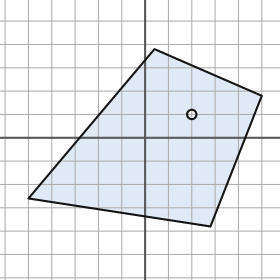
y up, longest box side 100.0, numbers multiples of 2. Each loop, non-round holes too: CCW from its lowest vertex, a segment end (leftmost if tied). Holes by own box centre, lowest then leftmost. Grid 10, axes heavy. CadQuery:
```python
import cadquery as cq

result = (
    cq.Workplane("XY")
    .moveTo(28.0, -38.0)
    .lineTo(50.0, 18.0)
    .lineTo(4.0, 38.0)
    .lineTo(-50.0, -26.0)
    .close()
    .moveTo(20.0, 10.0)
    .circle(2.0)
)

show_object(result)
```